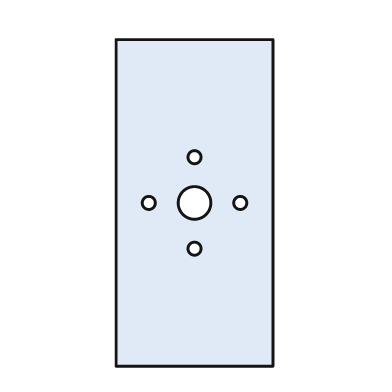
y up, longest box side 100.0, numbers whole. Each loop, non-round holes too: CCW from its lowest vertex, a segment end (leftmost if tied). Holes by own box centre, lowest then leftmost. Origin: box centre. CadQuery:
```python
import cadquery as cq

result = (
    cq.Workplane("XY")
    .moveTo(-24.0, -50.0)
    .lineTo(24.0, -50.0)
    .lineTo(24.0, 50.0)
    .lineTo(-24.0, 50.0)
    .close()
    .moveTo(0.0, -14.0)
    .circle(2.0)
    .moveTo(-14.0, 0.0)
    .circle(2.0)
    .moveTo(0.0, 0.0)
    .circle(5.0)
    .moveTo(14.0, 0.0)
    .circle(2.0)
    .moveTo(0.0, 14.0)
    .circle(2.0)
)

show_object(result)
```